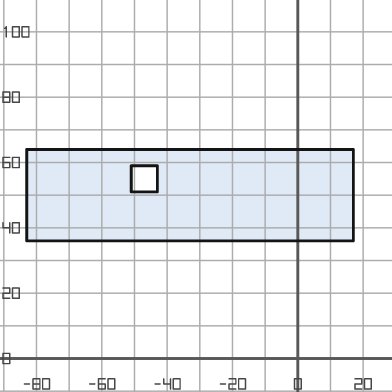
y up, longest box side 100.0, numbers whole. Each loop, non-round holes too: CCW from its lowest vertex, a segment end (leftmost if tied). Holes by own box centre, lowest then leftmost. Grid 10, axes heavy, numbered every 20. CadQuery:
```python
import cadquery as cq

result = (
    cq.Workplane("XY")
    .moveTo(-83.0, 36.0)
    .lineTo(17.0, 36.0)
    .lineTo(17.0, 64.0)
    .lineTo(-83.0, 64.0)
    .close()
    .moveTo(-51.0, 51.0)
    .lineTo(-43.0, 51.0)
    .lineTo(-43.0, 59.0)
    .lineTo(-51.0, 59.0)
    .close()
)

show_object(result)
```